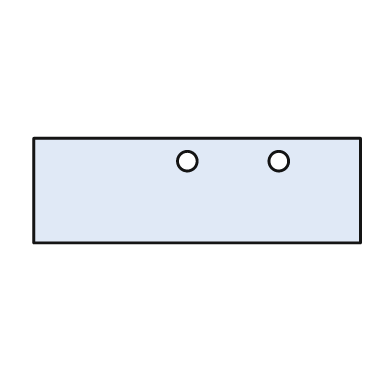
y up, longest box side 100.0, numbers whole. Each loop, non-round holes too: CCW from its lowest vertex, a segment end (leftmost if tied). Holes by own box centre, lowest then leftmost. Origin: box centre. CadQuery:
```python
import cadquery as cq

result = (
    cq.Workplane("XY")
    .moveTo(-50.0, -16.0)
    .lineTo(50.0, -16.0)
    .lineTo(50.0, 16.0)
    .lineTo(-50.0, 16.0)
    .close()
    .moveTo(-3.0, 9.0)
    .circle(3.0)
    .moveTo(25.0, 9.0)
    .circle(3.0)
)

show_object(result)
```